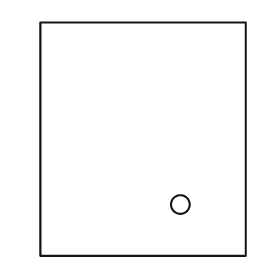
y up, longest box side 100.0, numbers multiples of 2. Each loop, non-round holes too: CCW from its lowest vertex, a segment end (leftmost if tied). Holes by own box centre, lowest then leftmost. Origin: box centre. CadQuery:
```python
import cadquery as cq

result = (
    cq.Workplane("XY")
    .moveTo(-44.0, -50.0)
    .lineTo(44.0, -50.0)
    .lineTo(44.0, 50.0)
    .lineTo(-44.0, 50.0)
    .close()
    .moveTo(16.0, -28.0)
    .circle(4.0)
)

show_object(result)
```